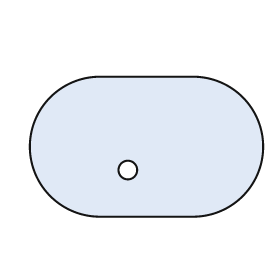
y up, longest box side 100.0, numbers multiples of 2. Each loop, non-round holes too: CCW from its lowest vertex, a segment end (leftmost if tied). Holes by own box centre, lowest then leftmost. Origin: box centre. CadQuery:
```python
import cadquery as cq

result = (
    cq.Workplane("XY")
    .moveTo(-20.0, -30.0)
    .lineTo(20.0, -30.0)
    .threePointArc((50.0, 0.0), (20.0, 30.0))
    .lineTo(-20.0, 30.0)
    .threePointArc((-50.0, 0.0), (-20.0, -30.0))
    .close()
    .moveTo(-8.0, -10.0)
    .circle(4.0)
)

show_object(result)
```